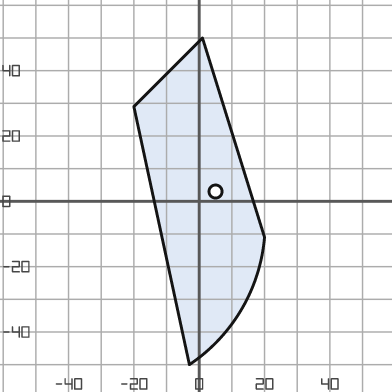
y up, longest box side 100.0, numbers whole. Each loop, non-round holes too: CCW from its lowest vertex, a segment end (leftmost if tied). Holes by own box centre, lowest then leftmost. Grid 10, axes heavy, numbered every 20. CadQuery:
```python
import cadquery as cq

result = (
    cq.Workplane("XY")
    .moveTo(-3.0, -50.0)
    .threePointArc((13.0, -33.0), (20.0, -11.0))
    .lineTo(1.0, 50.0)
    .lineTo(-20.0, 29.0)
    .close()
    .moveTo(5.0, 3.0)
    .circle(2.0)
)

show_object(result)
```